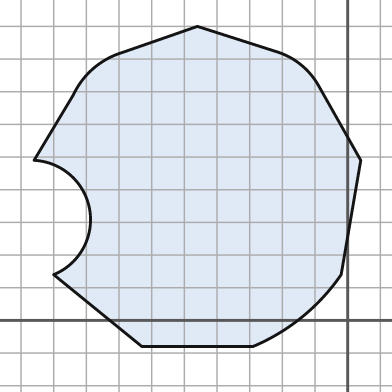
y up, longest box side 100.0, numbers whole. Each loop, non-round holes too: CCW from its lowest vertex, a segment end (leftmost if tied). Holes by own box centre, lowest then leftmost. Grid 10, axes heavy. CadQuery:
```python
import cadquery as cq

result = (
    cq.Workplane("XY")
    .moveTo(-63.0, -8.0)
    .lineTo(-29.0, -8.0)
    .threePointArc((-14.0, 1.0), (-2.0, 14.0))
    .lineTo(4.0, 49.0)
    .lineTo(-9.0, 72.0)
    .threePointArc((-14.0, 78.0), (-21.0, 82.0))
    .lineTo(-46.0, 90.0)
    .lineTo(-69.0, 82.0)
    .threePointArc((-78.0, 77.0), (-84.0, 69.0))
    .lineTo(-96.0, 49.0)
    .threePointArc((-79.0, 34.0), (-90.0, 14.0))
    .close()
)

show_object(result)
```